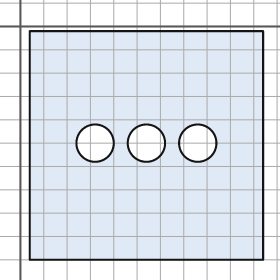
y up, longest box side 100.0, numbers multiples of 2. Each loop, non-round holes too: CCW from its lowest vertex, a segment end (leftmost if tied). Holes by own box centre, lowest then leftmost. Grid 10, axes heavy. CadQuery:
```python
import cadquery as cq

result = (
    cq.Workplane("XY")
    .moveTo(4.0, -100.0)
    .lineTo(104.0, -100.0)
    .lineTo(104.0, -2.0)
    .lineTo(4.0, -2.0)
    .close()
    .moveTo(32.0, -50.0)
    .circle(8.0)
    .moveTo(54.0, -50.0)
    .circle(8.0)
    .moveTo(76.0, -50.0)
    .circle(8.0)
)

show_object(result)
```